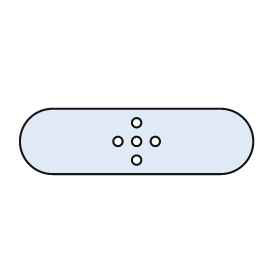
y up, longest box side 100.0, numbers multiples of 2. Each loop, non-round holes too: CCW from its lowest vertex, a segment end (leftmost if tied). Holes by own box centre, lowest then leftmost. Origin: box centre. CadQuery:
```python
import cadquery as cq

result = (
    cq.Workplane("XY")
    .moveTo(-36.0, -14.0)
    .lineTo(36.0, -14.0)
    .threePointArc((50.0, 0.0), (36.0, 14.0))
    .lineTo(-36.0, 14.0)
    .threePointArc((-50.0, 0.0), (-36.0, -14.0))
    .close()
    .moveTo(0.0, -8.0)
    .circle(2.0)
    .moveTo(-8.0, 0.0)
    .circle(2.0)
    .moveTo(0.0, 0.0)
    .circle(2.0)
    .moveTo(8.0, 0.0)
    .circle(2.0)
    .moveTo(0.0, 8.0)
    .circle(2.0)
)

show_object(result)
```